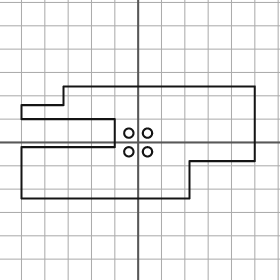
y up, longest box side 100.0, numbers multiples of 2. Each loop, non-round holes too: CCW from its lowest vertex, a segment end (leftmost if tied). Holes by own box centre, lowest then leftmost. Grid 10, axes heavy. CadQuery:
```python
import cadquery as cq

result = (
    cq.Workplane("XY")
    .moveTo(-50.0, -24.0)
    .lineTo(22.0, -24.0)
    .lineTo(22.0, -8.0)
    .lineTo(50.0, -8.0)
    .lineTo(50.0, 24.0)
    .lineTo(-32.0, 24.0)
    .lineTo(-32.0, 16.0)
    .lineTo(-50.0, 16.0)
    .lineTo(-50.0, 10.0)
    .lineTo(-10.0, 10.0)
    .lineTo(-10.0, -2.0)
    .lineTo(-50.0, -2.0)
    .close()
    .moveTo(-4.0, -4.0)
    .circle(2.0)
    .moveTo(4.0, -4.0)
    .circle(2.0)
    .moveTo(-4.0, 4.0)
    .circle(2.0)
    .moveTo(4.0, 4.0)
    .circle(2.0)
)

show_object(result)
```